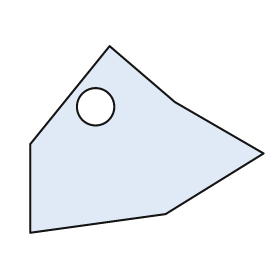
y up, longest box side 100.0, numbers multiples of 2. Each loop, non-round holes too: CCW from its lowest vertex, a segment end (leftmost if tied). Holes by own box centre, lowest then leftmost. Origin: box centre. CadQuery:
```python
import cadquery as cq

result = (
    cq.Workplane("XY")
    .moveTo(-50.0, -40.0)
    .lineTo(8.0, -32.0)
    .lineTo(50.0, -6.0)
    .lineTo(12.0, 16.0)
    .lineTo(-16.0, 40.0)
    .lineTo(-50.0, -2.0)
    .close()
    .moveTo(-22.0, 14.0)
    .circle(8.0)
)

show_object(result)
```